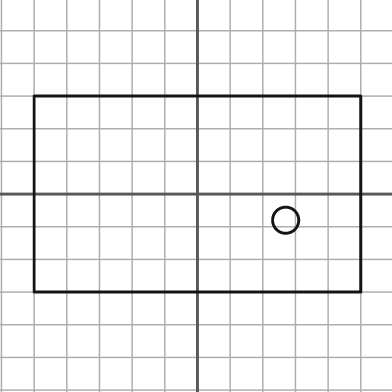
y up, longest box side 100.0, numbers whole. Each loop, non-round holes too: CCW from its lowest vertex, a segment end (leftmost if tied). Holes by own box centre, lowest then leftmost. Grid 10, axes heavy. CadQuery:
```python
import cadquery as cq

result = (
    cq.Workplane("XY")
    .moveTo(-50.0, -30.0)
    .lineTo(50.0, -30.0)
    .lineTo(50.0, 30.0)
    .lineTo(-50.0, 30.0)
    .close()
    .moveTo(27.0, -8.0)
    .circle(4.0)
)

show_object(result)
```